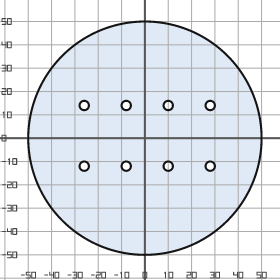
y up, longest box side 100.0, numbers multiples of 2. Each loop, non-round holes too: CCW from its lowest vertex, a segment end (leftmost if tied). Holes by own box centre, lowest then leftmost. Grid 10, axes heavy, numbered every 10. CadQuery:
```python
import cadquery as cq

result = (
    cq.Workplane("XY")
    .moveTo(0.0, 0.0)
    .circle(50.0)
    .moveTo(-26.0, -12.0)
    .circle(2.0)
    .moveTo(-8.0, -12.0)
    .circle(2.0)
    .moveTo(10.0, -12.0)
    .circle(2.0)
    .moveTo(28.0, -12.0)
    .circle(2.0)
    .moveTo(-26.0, 14.0)
    .circle(2.0)
    .moveTo(-8.0, 14.0)
    .circle(2.0)
    .moveTo(10.0, 14.0)
    .circle(2.0)
    .moveTo(28.0, 14.0)
    .circle(2.0)
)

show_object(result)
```